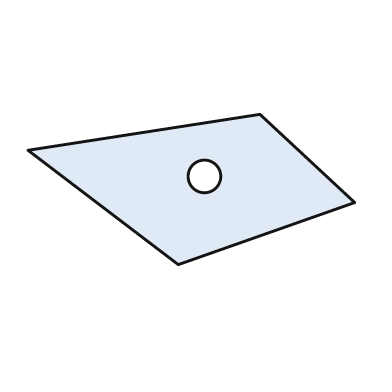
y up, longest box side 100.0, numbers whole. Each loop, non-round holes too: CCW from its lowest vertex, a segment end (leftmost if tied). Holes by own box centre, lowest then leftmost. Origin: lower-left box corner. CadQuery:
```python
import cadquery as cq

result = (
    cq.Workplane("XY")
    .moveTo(46.0, 0.0)
    .lineTo(100.0, 19.0)
    .lineTo(71.0, 46.0)
    .lineTo(0.0, 35.0)
    .close()
    .moveTo(54.0, 27.0)
    .circle(5.0)
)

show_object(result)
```